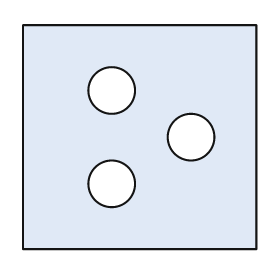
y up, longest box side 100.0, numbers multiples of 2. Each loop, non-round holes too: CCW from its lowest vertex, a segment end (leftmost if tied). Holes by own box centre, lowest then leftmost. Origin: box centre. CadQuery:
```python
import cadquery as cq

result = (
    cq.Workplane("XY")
    .moveTo(-50.0, -48.0)
    .lineTo(50.0, -48.0)
    .lineTo(50.0, 48.0)
    .lineTo(-50.0, 48.0)
    .close()
    .moveTo(-12.0, -20.0)
    .circle(10.0)
    .moveTo(22.0, 0.0)
    .circle(10.0)
    .moveTo(-12.0, 20.0)
    .circle(10.0)
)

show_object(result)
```